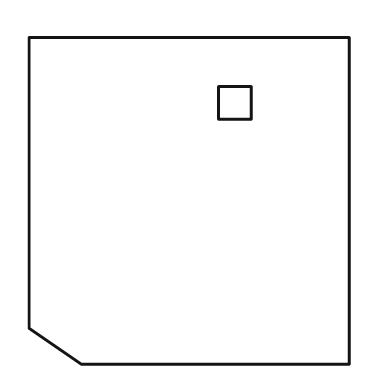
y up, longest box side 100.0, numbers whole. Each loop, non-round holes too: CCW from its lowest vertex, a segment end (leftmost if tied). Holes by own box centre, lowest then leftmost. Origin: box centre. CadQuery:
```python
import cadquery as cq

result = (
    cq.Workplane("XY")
    .moveTo(-33.0, -50.0)
    .lineTo(49.0, -50.0)
    .lineTo(49.0, 50.0)
    .lineTo(-49.0, 50.0)
    .lineTo(-49.0, -39.0)
    .close()
    .moveTo(9.0, 25.0)
    .lineTo(19.0, 25.0)
    .lineTo(19.0, 35.0)
    .lineTo(9.0, 35.0)
    .close()
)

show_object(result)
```